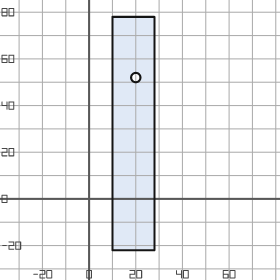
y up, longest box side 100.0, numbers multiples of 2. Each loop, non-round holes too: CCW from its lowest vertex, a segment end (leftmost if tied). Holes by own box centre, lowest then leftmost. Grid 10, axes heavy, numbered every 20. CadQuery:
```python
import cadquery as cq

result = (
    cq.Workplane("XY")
    .moveTo(10.0, -22.0)
    .lineTo(28.0, -22.0)
    .lineTo(28.0, 78.0)
    .lineTo(10.0, 78.0)
    .close()
    .moveTo(20.0, 52.0)
    .circle(2.0)
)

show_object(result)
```